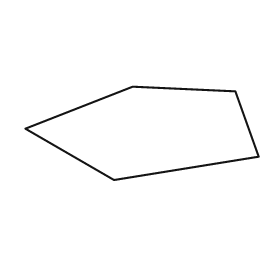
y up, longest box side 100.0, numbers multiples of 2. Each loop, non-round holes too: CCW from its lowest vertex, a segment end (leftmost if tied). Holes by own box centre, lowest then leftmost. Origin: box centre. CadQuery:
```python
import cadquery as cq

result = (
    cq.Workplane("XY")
    .moveTo(-12.0, -20.0)
    .lineTo(50.0, -10.0)
    .lineTo(40.0, 18.0)
    .lineTo(-4.0, 20.0)
    .lineTo(-50.0, 2.0)
    .close()
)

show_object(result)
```